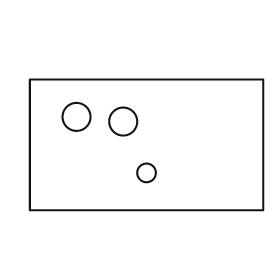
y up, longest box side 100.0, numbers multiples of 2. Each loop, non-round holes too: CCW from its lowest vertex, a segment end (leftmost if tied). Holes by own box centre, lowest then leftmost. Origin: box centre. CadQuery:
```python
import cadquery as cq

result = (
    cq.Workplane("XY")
    .moveTo(-50.0, -28.0)
    .lineTo(50.0, -28.0)
    .lineTo(50.0, 28.0)
    .lineTo(-50.0, 28.0)
    .close()
    .moveTo(0.0, -12.0)
    .circle(4.0)
    .moveTo(-10.0, 10.0)
    .circle(6.0)
    .moveTo(-30.0, 12.0)
    .circle(6.0)
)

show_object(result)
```